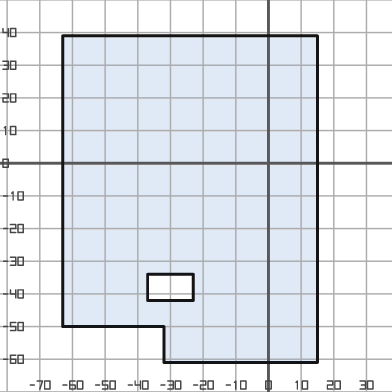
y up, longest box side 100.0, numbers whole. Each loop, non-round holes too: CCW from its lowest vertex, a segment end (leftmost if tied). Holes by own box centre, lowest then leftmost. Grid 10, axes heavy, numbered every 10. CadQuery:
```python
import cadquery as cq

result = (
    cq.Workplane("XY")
    .moveTo(-32.0, -61.0)
    .lineTo(15.0, -61.0)
    .lineTo(15.0, 39.0)
    .lineTo(-63.0, 39.0)
    .lineTo(-63.0, -50.0)
    .lineTo(-32.0, -50.0)
    .close()
    .moveTo(-37.0, -42.0)
    .lineTo(-23.0, -42.0)
    .lineTo(-23.0, -34.0)
    .lineTo(-37.0, -34.0)
    .close()
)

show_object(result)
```